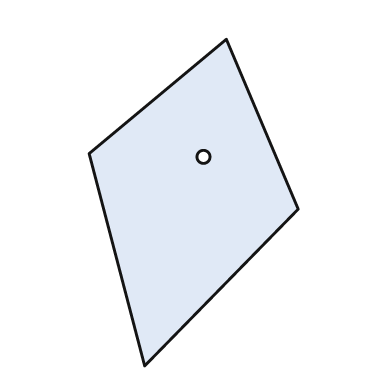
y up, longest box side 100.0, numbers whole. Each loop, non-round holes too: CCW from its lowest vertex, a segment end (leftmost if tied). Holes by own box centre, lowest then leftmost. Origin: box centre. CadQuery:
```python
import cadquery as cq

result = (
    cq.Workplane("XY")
    .moveTo(-15.0, -50.0)
    .lineTo(32.0, -2.0)
    .lineTo(10.0, 50.0)
    .lineTo(-32.0, 15.0)
    .close()
    .moveTo(3.0, 14.0)
    .circle(2.0)
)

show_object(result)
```